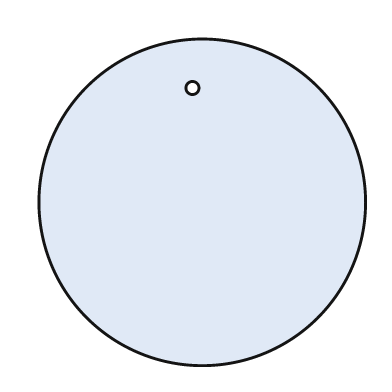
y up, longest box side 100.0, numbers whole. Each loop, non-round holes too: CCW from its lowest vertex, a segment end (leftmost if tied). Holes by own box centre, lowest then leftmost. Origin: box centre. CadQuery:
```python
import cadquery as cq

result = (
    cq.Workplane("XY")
    .moveTo(0.0, 0.0)
    .circle(50.0)
    .moveTo(-3.0, 35.0)
    .circle(2.0)
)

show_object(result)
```